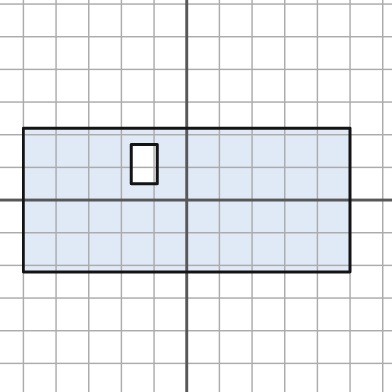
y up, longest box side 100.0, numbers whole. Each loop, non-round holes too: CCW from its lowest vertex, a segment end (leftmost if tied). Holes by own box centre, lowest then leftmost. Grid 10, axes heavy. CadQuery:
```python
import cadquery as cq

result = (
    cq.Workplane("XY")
    .moveTo(-50.0, -22.0)
    .lineTo(50.0, -22.0)
    .lineTo(50.0, 22.0)
    .lineTo(-50.0, 22.0)
    .close()
    .moveTo(-17.0, 5.0)
    .lineTo(-9.0, 5.0)
    .lineTo(-9.0, 17.0)
    .lineTo(-17.0, 17.0)
    .close()
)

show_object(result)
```